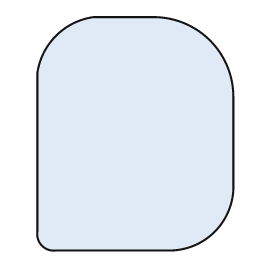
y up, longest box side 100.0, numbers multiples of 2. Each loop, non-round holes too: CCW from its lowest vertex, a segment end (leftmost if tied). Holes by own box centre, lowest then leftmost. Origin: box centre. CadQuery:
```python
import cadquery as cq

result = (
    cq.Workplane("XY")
    .moveTo(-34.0, -50.0)
    .lineTo(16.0, -50.0)
    .threePointArc((34.0, -42.0), (42.0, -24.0))
    .lineTo(42.0, 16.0)
    .threePointArc((32.0, 40.0), (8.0, 50.0))
    .lineTo(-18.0, 50.0)
    .threePointArc((-34.0, 42.0), (-42.0, 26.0))
    .lineTo(-42.0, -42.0)
    .threePointArc((-40.0, -48.0), (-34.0, -50.0))
    .close()
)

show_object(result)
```